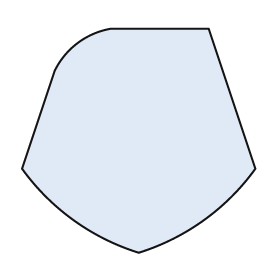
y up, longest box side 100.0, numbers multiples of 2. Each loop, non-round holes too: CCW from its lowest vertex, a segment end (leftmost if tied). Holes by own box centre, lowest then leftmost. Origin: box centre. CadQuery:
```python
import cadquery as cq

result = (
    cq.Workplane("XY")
    .moveTo(0.0, -48.0)
    .threePointArc((28.0, -34.0), (50.0, -12.0))
    .lineTo(30.0, 48.0)
    .lineTo(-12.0, 48.0)
    .threePointArc((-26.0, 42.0), (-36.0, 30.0))
    .lineTo(-50.0, -12.0)
    .threePointArc((-28.0, -34.0), (0.0, -48.0))
    .close()
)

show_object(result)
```